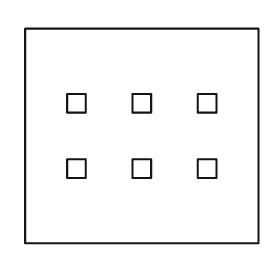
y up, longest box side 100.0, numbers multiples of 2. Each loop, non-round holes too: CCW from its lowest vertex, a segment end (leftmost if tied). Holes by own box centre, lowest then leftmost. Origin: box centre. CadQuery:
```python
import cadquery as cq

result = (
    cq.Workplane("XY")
    .moveTo(-50.0, -46.0)
    .lineTo(50.0, -46.0)
    .lineTo(50.0, 46.0)
    .lineTo(-50.0, 46.0)
    .close()
    .moveTo(-32.0, -18.0)
    .lineTo(-24.0, -18.0)
    .lineTo(-24.0, -10.0)
    .lineTo(-32.0, -10.0)
    .close()
    .moveTo(-4.0, -18.0)
    .lineTo(4.0, -18.0)
    .lineTo(4.0, -10.0)
    .lineTo(-4.0, -10.0)
    .close()
    .moveTo(24.0, -18.0)
    .lineTo(32.0, -18.0)
    .lineTo(32.0, -10.0)
    .lineTo(24.0, -10.0)
    .close()
    .moveTo(-32.0, 10.0)
    .lineTo(-24.0, 10.0)
    .lineTo(-24.0, 18.0)
    .lineTo(-32.0, 18.0)
    .close()
    .moveTo(-4.0, 10.0)
    .lineTo(4.0, 10.0)
    .lineTo(4.0, 18.0)
    .lineTo(-4.0, 18.0)
    .close()
    .moveTo(24.0, 10.0)
    .lineTo(32.0, 10.0)
    .lineTo(32.0, 18.0)
    .lineTo(24.0, 18.0)
    .close()
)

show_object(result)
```